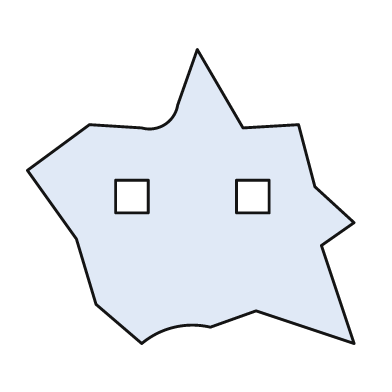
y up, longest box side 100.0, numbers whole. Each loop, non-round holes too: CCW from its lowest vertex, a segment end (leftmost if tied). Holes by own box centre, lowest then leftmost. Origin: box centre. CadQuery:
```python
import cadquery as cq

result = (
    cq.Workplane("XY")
    .moveTo(-15.0, -45.0)
    .threePointArc((-5.0, -40.0), (6.0, -40.0))
    .lineTo(20.0, -35.0)
    .lineTo(50.0, -45.0)
    .lineTo(40.0, -15.0)
    .lineTo(50.0, -8.0)
    .lineTo(38.0, 3.0)
    .lineTo(33.0, 22.0)
    .lineTo(16.0, 21.0)
    .lineTo(2.0, 45.0)
    .lineTo(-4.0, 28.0)
    .threePointArc((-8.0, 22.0), (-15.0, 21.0))
    .lineTo(-31.0, 22.0)
    .lineTo(-50.0, 8.0)
    .lineTo(-35.0, -13.0)
    .lineTo(-29.0, -33.0)
    .close()
    .moveTo(-23.0, -5.0)
    .lineTo(-13.0, -5.0)
    .lineTo(-13.0, 5.0)
    .lineTo(-23.0, 5.0)
    .close()
    .moveTo(14.0, -5.0)
    .lineTo(24.0, -5.0)
    .lineTo(24.0, 5.0)
    .lineTo(14.0, 5.0)
    .close()
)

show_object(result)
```